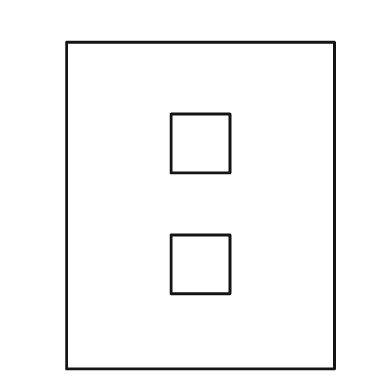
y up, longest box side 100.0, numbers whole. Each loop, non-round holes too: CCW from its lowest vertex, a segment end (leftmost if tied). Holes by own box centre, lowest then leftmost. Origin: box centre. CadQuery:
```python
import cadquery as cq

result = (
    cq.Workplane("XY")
    .moveTo(-41.0, -50.0)
    .lineTo(41.0, -50.0)
    .lineTo(41.0, 50.0)
    .lineTo(-41.0, 50.0)
    .close()
    .moveTo(-9.0, -27.0)
    .lineTo(9.0, -27.0)
    .lineTo(9.0, -9.0)
    .lineTo(-9.0, -9.0)
    .close()
    .moveTo(-9.0, 10.0)
    .lineTo(9.0, 10.0)
    .lineTo(9.0, 28.0)
    .lineTo(-9.0, 28.0)
    .close()
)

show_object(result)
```